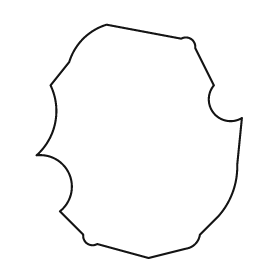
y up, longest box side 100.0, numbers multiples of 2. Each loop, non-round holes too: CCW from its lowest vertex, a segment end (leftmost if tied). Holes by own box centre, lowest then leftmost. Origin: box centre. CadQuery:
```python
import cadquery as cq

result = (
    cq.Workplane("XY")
    .moveTo(4.0, -50.0)
    .lineTo(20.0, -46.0)
    .threePointArc((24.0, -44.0), (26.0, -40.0))
    .lineTo(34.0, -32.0)
    .threePointArc((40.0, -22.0), (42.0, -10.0))
    .lineTo(44.0, 10.0)
    .threePointArc((32.0, 12.0), (32.0, 24.0))
    .lineTo(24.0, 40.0)
    .threePointArc((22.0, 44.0), (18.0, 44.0))
    .lineTo(-14.0, 50.0)
    .threePointArc((-24.0, 44.0), (-30.0, 34.0))
    .lineTo(-38.0, 24.0)
    .threePointArc((-36.0, 8.0), (-44.0, -6.0))
    .threePointArc((-30.0, -14.0), (-34.0, -30.0))
    .lineTo(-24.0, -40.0)
    .threePointArc((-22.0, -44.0), (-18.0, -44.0))
    .close()
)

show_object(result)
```